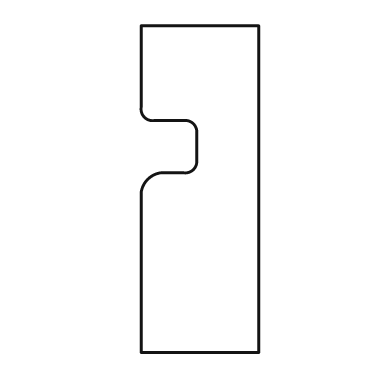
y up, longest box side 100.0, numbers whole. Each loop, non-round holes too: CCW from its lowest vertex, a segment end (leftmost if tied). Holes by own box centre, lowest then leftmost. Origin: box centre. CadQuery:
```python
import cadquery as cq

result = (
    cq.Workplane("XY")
    .moveTo(-18.0, -50.0)
    .lineTo(18.0, -50.0)
    .lineTo(18.0, 50.0)
    .lineTo(-18.0, 50.0)
    .lineTo(-18.0, 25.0)
    .threePointArc((-17.0, 22.0), (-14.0, 21.0))
    .lineTo(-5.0, 21.0)
    .threePointArc((-2.0, 20.0), (-1.0, 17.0))
    .lineTo(-1.0, 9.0)
    .threePointArc((-2.0, 6.0), (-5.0, 5.0))
    .lineTo(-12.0, 5.0)
    .threePointArc((-16.0, 3.0), (-18.0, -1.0))
    .close()
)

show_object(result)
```